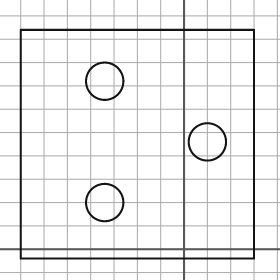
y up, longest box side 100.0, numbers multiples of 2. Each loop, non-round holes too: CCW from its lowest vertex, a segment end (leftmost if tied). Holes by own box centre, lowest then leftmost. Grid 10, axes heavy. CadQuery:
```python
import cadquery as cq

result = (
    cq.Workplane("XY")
    .moveTo(-70.0, -4.0)
    .lineTo(30.0, -4.0)
    .lineTo(30.0, 94.0)
    .lineTo(-70.0, 94.0)
    .close()
    .moveTo(-34.0, 20.0)
    .circle(8.0)
    .moveTo(10.0, 46.0)
    .circle(8.0)
    .moveTo(-34.0, 72.0)
    .circle(8.0)
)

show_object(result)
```